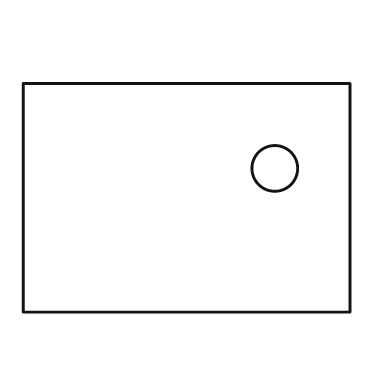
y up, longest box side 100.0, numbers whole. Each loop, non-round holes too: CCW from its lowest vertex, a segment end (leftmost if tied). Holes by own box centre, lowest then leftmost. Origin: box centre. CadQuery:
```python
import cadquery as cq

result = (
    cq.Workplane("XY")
    .moveTo(-50.0, -35.0)
    .lineTo(50.0, -35.0)
    .lineTo(50.0, 35.0)
    .lineTo(-50.0, 35.0)
    .close()
    .moveTo(27.0, 9.0)
    .circle(7.0)
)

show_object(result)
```